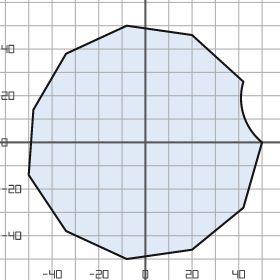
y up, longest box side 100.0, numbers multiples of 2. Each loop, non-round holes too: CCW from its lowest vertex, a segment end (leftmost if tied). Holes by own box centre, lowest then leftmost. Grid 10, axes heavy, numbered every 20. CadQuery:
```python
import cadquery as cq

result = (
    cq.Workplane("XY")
    .moveTo(-8.0, -50.0)
    .lineTo(20.0, -46.0)
    .lineTo(42.0, -28.0)
    .lineTo(50.0, 0.0)
    .threePointArc((42.0, 12.0), (42.0, 26.0))
    .lineTo(20.0, 46.0)
    .lineTo(-8.0, 50.0)
    .lineTo(-34.0, 38.0)
    .lineTo(-48.0, 14.0)
    .lineTo(-50.0, -14.0)
    .lineTo(-34.0, -38.0)
    .close()
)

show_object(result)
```